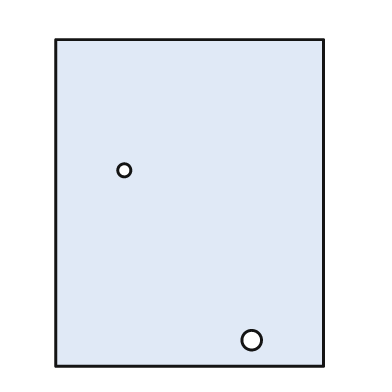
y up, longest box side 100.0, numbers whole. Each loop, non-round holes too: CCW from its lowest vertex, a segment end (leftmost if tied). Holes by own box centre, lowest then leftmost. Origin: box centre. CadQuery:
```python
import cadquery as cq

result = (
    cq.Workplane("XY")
    .moveTo(-41.0, -50.0)
    .lineTo(41.0, -50.0)
    .lineTo(41.0, 50.0)
    .lineTo(-41.0, 50.0)
    .close()
    .moveTo(19.0, -42.0)
    .circle(3.0)
    .moveTo(-20.0, 10.0)
    .circle(2.0)
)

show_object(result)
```